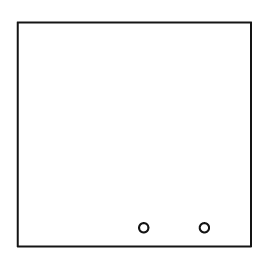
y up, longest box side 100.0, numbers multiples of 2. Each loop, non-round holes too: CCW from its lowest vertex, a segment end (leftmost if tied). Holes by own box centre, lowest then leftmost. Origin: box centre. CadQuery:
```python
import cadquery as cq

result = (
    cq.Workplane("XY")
    .moveTo(-50.0, -48.0)
    .lineTo(50.0, -48.0)
    .lineTo(50.0, 48.0)
    .lineTo(-50.0, 48.0)
    .close()
    .moveTo(4.0, -40.0)
    .circle(2.0)
    .moveTo(30.0, -40.0)
    .circle(2.0)
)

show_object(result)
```